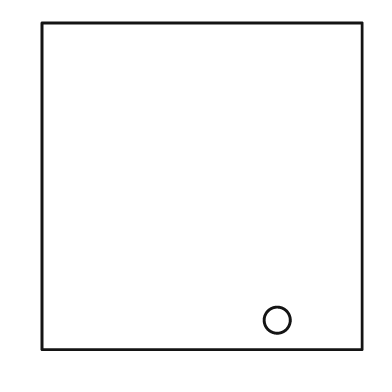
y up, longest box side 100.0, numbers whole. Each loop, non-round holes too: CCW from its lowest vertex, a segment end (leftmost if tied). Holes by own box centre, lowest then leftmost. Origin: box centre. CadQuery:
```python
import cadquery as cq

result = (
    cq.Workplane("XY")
    .moveTo(-49.0, -50.0)
    .lineTo(49.0, -50.0)
    .lineTo(49.0, 50.0)
    .lineTo(-49.0, 50.0)
    .close()
    .moveTo(23.0, -41.0)
    .circle(4.0)
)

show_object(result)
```